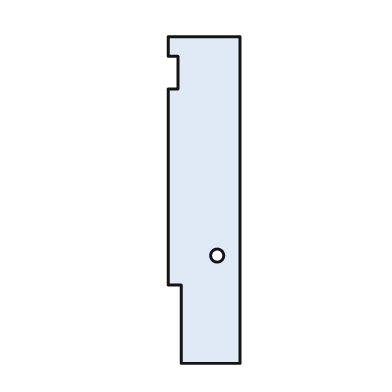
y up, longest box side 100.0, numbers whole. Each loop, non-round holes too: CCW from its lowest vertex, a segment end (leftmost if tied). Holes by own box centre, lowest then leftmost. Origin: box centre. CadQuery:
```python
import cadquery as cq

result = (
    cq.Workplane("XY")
    .moveTo(-7.0, -50.0)
    .lineTo(11.0, -50.0)
    .lineTo(11.0, 50.0)
    .lineTo(-11.0, 50.0)
    .lineTo(-11.0, 44.0)
    .lineTo(-8.0, 44.0)
    .lineTo(-8.0, 34.0)
    .lineTo(-11.0, 34.0)
    .lineTo(-11.0, -26.0)
    .lineTo(-7.0, -26.0)
    .close()
    .moveTo(4.0, -17.0)
    .circle(2.0)
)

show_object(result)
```